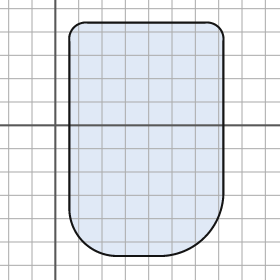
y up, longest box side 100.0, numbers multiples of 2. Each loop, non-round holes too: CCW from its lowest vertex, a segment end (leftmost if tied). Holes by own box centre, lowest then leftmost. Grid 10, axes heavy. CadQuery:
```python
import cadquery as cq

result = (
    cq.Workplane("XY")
    .moveTo(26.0, -56.0)
    .lineTo(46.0, -56.0)
    .threePointArc((64.0, -48.0), (72.0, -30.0))
    .lineTo(72.0, 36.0)
    .threePointArc((70.0, 42.0), (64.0, 44.0))
    .lineTo(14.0, 44.0)
    .threePointArc((8.0, 42.0), (6.0, 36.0))
    .lineTo(6.0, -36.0)
    .threePointArc((12.0, -50.0), (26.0, -56.0))
    .close()
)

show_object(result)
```